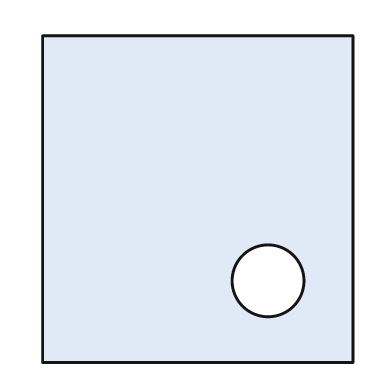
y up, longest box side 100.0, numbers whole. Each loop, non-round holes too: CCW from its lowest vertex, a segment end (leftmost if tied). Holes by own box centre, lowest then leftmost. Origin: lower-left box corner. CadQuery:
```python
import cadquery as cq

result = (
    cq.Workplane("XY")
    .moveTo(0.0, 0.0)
    .lineTo(95.0, 0.0)
    .lineTo(95.0, 100.0)
    .lineTo(0.0, 100.0)
    .close()
    .moveTo(69.0, 25.0)
    .circle(11.0)
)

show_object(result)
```